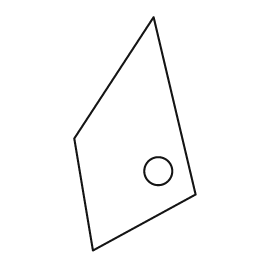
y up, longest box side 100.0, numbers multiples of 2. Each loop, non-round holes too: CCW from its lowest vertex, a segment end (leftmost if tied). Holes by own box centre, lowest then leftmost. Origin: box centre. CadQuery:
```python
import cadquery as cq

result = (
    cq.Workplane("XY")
    .moveTo(-18.0, -50.0)
    .lineTo(26.0, -26.0)
    .lineTo(8.0, 50.0)
    .lineTo(-26.0, -2.0)
    .close()
    .moveTo(10.0, -16.0)
    .circle(6.0)
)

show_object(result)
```